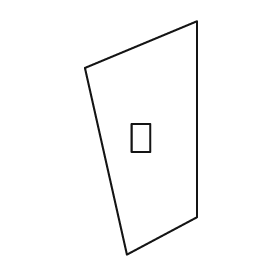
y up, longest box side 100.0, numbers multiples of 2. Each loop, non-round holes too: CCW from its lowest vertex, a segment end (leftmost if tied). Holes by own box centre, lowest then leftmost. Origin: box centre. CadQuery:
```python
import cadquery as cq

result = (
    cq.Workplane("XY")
    .moveTo(-6.0, -50.0)
    .lineTo(24.0, -34.0)
    .lineTo(24.0, 50.0)
    .lineTo(-24.0, 30.0)
    .close()
    .moveTo(-4.0, -6.0)
    .lineTo(4.0, -6.0)
    .lineTo(4.0, 6.0)
    .lineTo(-4.0, 6.0)
    .close()
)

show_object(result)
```